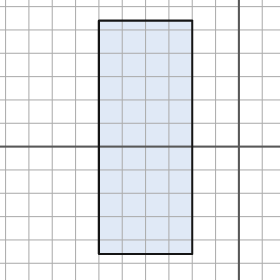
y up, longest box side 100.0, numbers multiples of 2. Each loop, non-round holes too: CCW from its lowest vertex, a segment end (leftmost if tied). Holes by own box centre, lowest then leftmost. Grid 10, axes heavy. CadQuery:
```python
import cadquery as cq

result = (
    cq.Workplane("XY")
    .moveTo(-60.0, -46.0)
    .lineTo(-20.0, -46.0)
    .lineTo(-20.0, 54.0)
    .lineTo(-60.0, 54.0)
    .close()
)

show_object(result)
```